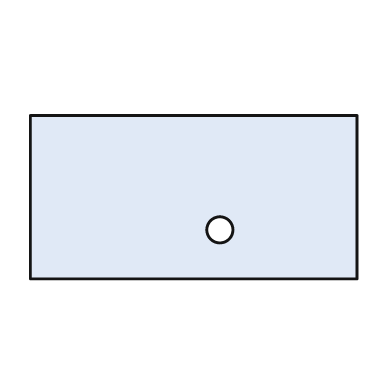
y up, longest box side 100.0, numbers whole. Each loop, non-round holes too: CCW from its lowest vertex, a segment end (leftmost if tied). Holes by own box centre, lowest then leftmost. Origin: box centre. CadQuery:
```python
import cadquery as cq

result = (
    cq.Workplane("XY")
    .moveTo(-50.0, -25.0)
    .lineTo(50.0, -25.0)
    .lineTo(50.0, 25.0)
    .lineTo(-50.0, 25.0)
    .close()
    .moveTo(8.0, -10.0)
    .circle(4.0)
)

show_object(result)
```